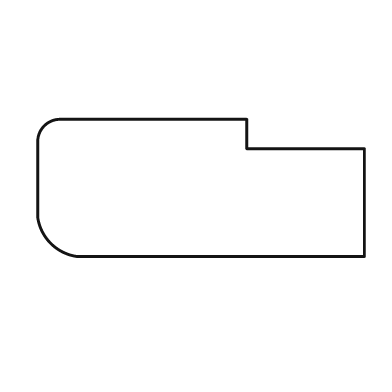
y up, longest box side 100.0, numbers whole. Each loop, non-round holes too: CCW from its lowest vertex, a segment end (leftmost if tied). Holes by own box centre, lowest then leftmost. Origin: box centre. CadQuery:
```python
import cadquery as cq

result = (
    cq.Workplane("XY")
    .moveTo(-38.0, -21.0)
    .lineTo(50.0, -21.0)
    .lineTo(50.0, 12.0)
    .lineTo(14.0, 12.0)
    .lineTo(14.0, 21.0)
    .lineTo(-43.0, 21.0)
    .threePointArc((-48.0, 19.0), (-50.0, 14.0))
    .lineTo(-50.0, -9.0)
    .threePointArc((-46.0, -17.0), (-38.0, -21.0))
    .close()
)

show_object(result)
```